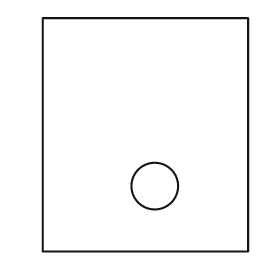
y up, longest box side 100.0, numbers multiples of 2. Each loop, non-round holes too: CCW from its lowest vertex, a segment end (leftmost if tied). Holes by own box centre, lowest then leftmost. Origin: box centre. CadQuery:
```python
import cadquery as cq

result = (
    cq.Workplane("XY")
    .moveTo(-44.0, -50.0)
    .lineTo(44.0, -50.0)
    .lineTo(44.0, 50.0)
    .lineTo(-44.0, 50.0)
    .close()
    .moveTo(4.0, -22.0)
    .circle(10.0)
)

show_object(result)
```